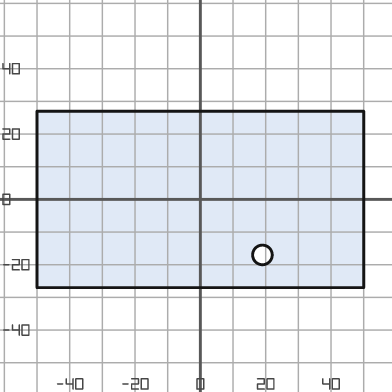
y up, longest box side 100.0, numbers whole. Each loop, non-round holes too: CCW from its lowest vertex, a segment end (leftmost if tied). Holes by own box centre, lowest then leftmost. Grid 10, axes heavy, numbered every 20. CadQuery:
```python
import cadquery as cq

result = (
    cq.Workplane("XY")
    .moveTo(-50.0, -27.0)
    .lineTo(50.0, -27.0)
    .lineTo(50.0, 27.0)
    .lineTo(-50.0, 27.0)
    .close()
    .moveTo(19.0, -17.0)
    .circle(3.0)
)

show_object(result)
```